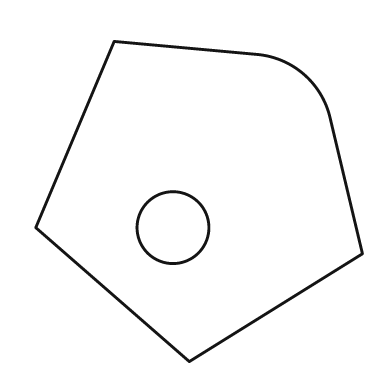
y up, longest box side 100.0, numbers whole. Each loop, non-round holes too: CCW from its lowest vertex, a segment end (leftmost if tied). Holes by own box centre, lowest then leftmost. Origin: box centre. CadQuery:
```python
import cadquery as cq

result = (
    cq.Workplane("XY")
    .moveTo(-3.0, -49.0)
    .lineTo(50.0, -16.0)
    .lineTo(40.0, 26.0)
    .threePointArc((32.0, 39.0), (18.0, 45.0))
    .lineTo(-26.0, 49.0)
    .lineTo(-50.0, -8.0)
    .close()
    .moveTo(-8.0, -8.0)
    .circle(11.0)
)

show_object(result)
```